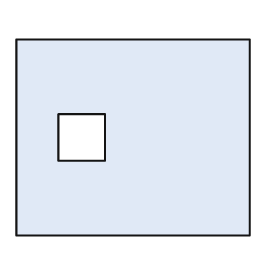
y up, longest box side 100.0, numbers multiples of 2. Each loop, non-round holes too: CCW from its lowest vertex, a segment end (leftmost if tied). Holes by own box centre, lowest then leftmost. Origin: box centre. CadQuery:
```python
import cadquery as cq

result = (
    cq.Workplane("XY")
    .moveTo(-50.0, -42.0)
    .lineTo(50.0, -42.0)
    .lineTo(50.0, 42.0)
    .lineTo(-50.0, 42.0)
    .close()
    .moveTo(-32.0, -10.0)
    .lineTo(-12.0, -10.0)
    .lineTo(-12.0, 10.0)
    .lineTo(-32.0, 10.0)
    .close()
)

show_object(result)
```